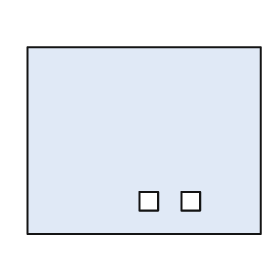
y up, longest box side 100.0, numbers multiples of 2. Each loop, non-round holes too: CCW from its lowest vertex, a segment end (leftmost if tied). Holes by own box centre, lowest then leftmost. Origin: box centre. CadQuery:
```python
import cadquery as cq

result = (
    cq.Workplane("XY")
    .moveTo(-50.0, -40.0)
    .lineTo(50.0, -40.0)
    .lineTo(50.0, 40.0)
    .lineTo(-50.0, 40.0)
    .close()
    .moveTo(-2.0, -30.0)
    .lineTo(6.0, -30.0)
    .lineTo(6.0, -22.0)
    .lineTo(-2.0, -22.0)
    .close()
    .moveTo(16.0, -30.0)
    .lineTo(24.0, -30.0)
    .lineTo(24.0, -22.0)
    .lineTo(16.0, -22.0)
    .close()
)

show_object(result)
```